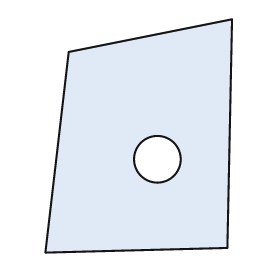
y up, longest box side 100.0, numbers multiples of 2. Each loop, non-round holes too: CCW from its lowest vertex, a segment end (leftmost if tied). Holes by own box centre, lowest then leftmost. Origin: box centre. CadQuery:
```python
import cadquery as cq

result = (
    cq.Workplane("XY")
    .moveTo(-40.0, -50.0)
    .lineTo(38.0, -48.0)
    .lineTo(40.0, 50.0)
    .lineTo(-30.0, 36.0)
    .close()
    .moveTo(8.0, -10.0)
    .circle(10.0)
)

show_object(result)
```